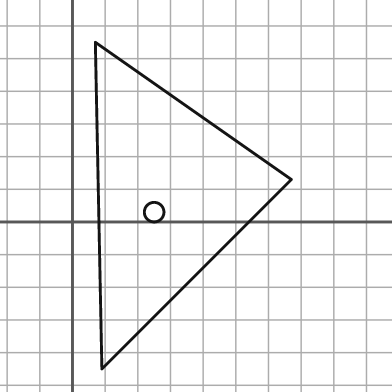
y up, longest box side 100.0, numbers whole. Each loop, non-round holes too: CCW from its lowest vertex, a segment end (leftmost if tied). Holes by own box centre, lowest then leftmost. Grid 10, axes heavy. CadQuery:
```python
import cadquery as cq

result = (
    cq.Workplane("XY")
    .moveTo(9.0, -45.0)
    .lineTo(67.0, 13.0)
    .lineTo(7.0, 55.0)
    .close()
    .moveTo(25.0, 3.0)
    .circle(3.0)
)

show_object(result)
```